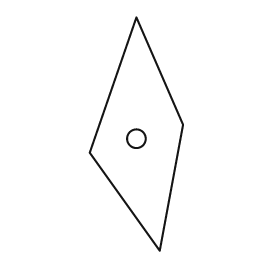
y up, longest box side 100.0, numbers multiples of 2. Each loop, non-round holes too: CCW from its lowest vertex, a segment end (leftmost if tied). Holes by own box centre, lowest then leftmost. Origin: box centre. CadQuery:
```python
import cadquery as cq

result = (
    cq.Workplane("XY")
    .moveTo(10.0, -50.0)
    .lineTo(20.0, 4.0)
    .lineTo(0.0, 50.0)
    .lineTo(-20.0, -8.0)
    .close()
    .moveTo(0.0, -2.0)
    .circle(4.0)
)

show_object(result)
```